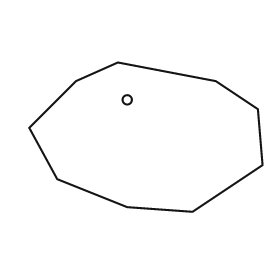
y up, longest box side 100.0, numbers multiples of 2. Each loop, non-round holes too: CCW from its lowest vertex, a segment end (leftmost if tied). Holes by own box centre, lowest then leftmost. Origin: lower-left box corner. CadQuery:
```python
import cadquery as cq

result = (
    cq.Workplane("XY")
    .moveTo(70.0, 0.0)
    .lineTo(100.0, 20.0)
    .lineTo(98.0, 44.0)
    .lineTo(80.0, 56.0)
    .lineTo(38.0, 64.0)
    .lineTo(20.0, 56.0)
    .lineTo(0.0, 36.0)
    .lineTo(12.0, 14.0)
    .lineTo(42.0, 2.0)
    .close()
    .moveTo(42.0, 48.0)
    .circle(2.0)
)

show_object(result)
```